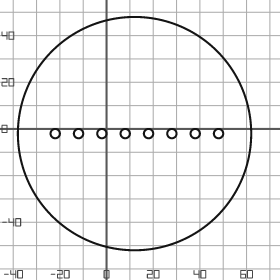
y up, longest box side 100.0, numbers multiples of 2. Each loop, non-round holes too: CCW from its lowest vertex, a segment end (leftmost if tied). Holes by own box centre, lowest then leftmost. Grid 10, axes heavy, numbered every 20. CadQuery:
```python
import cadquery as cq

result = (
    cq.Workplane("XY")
    .moveTo(12.0, -2.0)
    .circle(50.0)
    .moveTo(-22.0, -2.0)
    .circle(2.0)
    .moveTo(-12.0, -2.0)
    .circle(2.0)
    .moveTo(-2.0, -2.0)
    .circle(2.0)
    .moveTo(8.0, -2.0)
    .circle(2.0)
    .moveTo(18.0, -2.0)
    .circle(2.0)
    .moveTo(28.0, -2.0)
    .circle(2.0)
    .moveTo(38.0, -2.0)
    .circle(2.0)
    .moveTo(48.0, -2.0)
    .circle(2.0)
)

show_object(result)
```